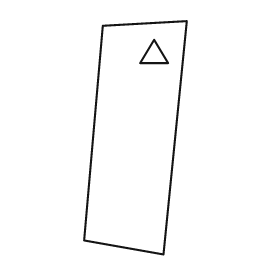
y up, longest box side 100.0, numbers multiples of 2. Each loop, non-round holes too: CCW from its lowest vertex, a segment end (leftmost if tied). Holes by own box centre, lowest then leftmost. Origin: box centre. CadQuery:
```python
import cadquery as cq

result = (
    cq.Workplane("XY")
    .moveTo(12.0, -50.0)
    .lineTo(22.0, 50.0)
    .lineTo(-14.0, 48.0)
    .lineTo(-22.0, -44.0)
    .close()
    .moveTo(2.0, 32.0)
    .lineTo(14.0, 32.0)
    .lineTo(8.0, 42.0)
    .close()
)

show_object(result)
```